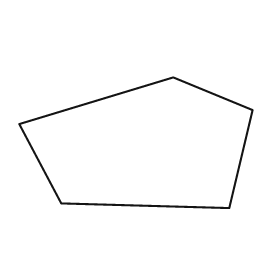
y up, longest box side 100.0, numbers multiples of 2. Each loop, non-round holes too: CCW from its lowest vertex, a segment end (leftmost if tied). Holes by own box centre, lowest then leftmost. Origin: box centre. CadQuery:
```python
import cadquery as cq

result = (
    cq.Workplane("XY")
    .moveTo(40.0, -28.0)
    .lineTo(50.0, 14.0)
    .lineTo(16.0, 28.0)
    .lineTo(-50.0, 8.0)
    .lineTo(-32.0, -26.0)
    .close()
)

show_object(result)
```